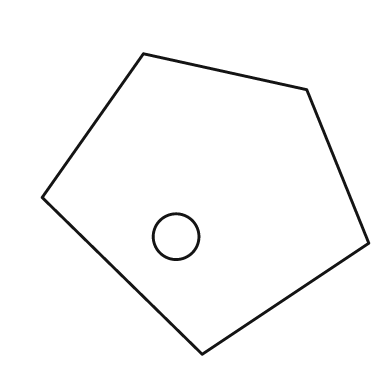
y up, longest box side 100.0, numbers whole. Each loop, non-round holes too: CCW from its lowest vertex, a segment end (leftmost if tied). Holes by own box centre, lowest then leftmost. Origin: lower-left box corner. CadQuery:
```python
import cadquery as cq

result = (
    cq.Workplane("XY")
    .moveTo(49.0, 0.0)
    .lineTo(100.0, 34.0)
    .lineTo(81.0, 81.0)
    .lineTo(31.0, 92.0)
    .lineTo(0.0, 48.0)
    .close()
    .moveTo(41.0, 36.0)
    .circle(7.0)
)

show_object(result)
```